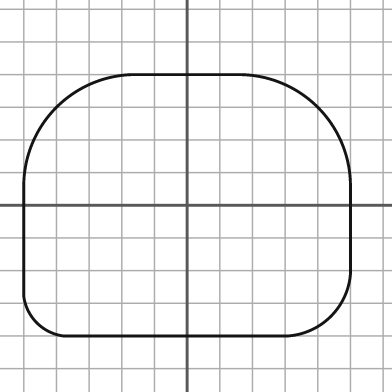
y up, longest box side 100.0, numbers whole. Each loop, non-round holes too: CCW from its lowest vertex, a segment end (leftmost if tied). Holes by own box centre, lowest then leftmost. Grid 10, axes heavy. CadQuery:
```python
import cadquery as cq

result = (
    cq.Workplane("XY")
    .moveTo(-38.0, -40.0)
    .lineTo(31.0, -40.0)
    .threePointArc((44.0, -34.0), (50.0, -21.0))
    .lineTo(50.0, 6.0)
    .threePointArc((40.0, 30.0), (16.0, 40.0))
    .lineTo(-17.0, 40.0)
    .threePointArc((-40.0, 30.0), (-50.0, 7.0))
    .lineTo(-50.0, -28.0)
    .threePointArc((-46.0, -36.0), (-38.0, -40.0))
    .close()
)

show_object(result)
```